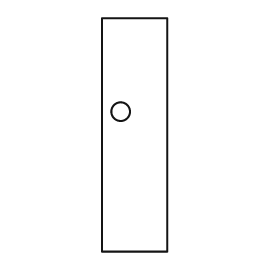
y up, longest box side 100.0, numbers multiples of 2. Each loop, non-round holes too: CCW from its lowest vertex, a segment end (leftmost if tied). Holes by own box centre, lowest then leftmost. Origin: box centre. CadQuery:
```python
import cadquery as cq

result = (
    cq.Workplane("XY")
    .moveTo(-14.0, -50.0)
    .lineTo(14.0, -50.0)
    .lineTo(14.0, 50.0)
    .lineTo(-14.0, 50.0)
    .close()
    .moveTo(-6.0, 10.0)
    .circle(4.0)
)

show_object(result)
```